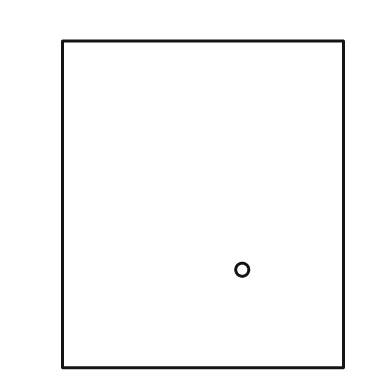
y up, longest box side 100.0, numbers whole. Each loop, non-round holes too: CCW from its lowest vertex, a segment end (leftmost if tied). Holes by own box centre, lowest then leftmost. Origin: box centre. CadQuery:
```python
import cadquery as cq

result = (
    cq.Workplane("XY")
    .moveTo(-43.0, -50.0)
    .lineTo(43.0, -50.0)
    .lineTo(43.0, 50.0)
    .lineTo(-43.0, 50.0)
    .close()
    .moveTo(12.0, -20.0)
    .circle(2.0)
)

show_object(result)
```